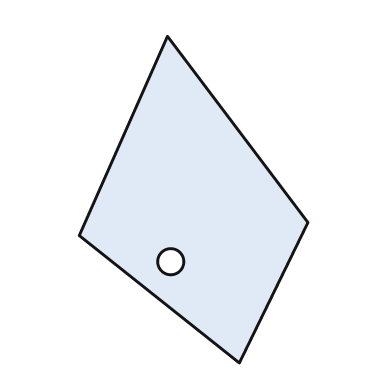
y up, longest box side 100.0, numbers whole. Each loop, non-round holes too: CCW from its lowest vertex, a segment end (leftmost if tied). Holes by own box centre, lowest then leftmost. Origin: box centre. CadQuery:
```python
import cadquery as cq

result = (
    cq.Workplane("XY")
    .moveTo(14.0, -50.0)
    .lineTo(35.0, -7.0)
    .lineTo(-8.0, 50.0)
    .lineTo(-35.0, -11.0)
    .close()
    .moveTo(-7.0, -19.0)
    .circle(4.0)
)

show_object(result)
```